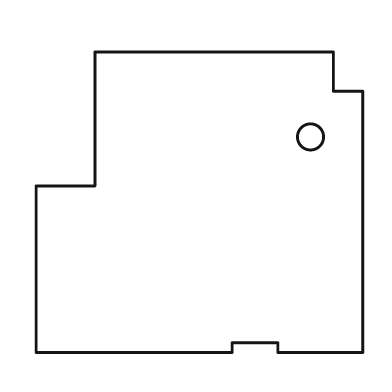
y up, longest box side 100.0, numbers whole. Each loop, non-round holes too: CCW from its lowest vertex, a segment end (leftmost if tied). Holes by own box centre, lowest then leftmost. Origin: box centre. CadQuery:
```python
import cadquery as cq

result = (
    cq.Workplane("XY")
    .moveTo(-50.0, -46.0)
    .lineTo(10.0, -46.0)
    .lineTo(10.0, -43.0)
    .lineTo(24.0, -43.0)
    .lineTo(24.0, -46.0)
    .lineTo(50.0, -46.0)
    .lineTo(50.0, 34.0)
    .lineTo(41.0, 34.0)
    .lineTo(41.0, 46.0)
    .lineTo(-32.0, 46.0)
    .lineTo(-32.0, 5.0)
    .lineTo(-50.0, 5.0)
    .close()
    .moveTo(34.0, 20.0)
    .circle(4.0)
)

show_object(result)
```